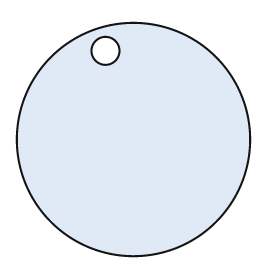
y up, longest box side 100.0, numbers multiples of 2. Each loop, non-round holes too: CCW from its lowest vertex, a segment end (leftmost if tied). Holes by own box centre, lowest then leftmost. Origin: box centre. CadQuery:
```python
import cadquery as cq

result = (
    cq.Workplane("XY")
    .moveTo(0.0, 0.0)
    .circle(50.0)
    .moveTo(-12.0, 38.0)
    .circle(6.0)
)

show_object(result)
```